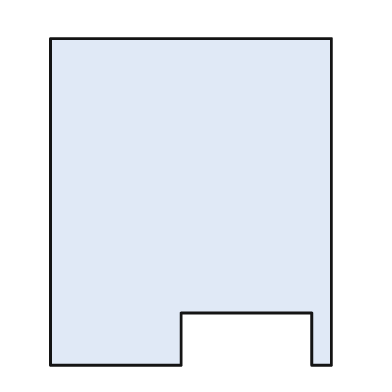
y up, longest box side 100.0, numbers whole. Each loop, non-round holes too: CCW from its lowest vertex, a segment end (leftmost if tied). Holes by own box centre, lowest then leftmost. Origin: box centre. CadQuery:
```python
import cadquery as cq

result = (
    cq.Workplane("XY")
    .moveTo(-43.0, -50.0)
    .lineTo(-3.0, -50.0)
    .lineTo(-3.0, -34.0)
    .lineTo(37.0, -34.0)
    .lineTo(37.0, -50.0)
    .lineTo(43.0, -50.0)
    .lineTo(43.0, 50.0)
    .lineTo(-43.0, 50.0)
    .close()
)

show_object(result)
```